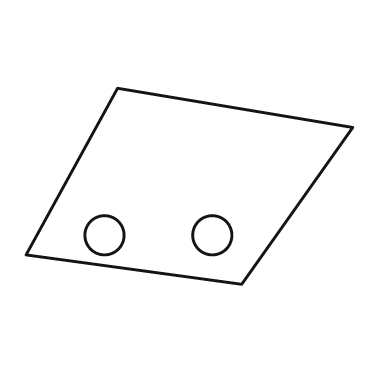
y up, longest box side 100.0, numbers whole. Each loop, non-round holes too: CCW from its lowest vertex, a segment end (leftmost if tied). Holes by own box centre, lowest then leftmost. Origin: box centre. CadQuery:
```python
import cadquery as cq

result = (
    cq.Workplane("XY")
    .moveTo(16.0, -30.0)
    .lineTo(50.0, 18.0)
    .lineTo(-22.0, 30.0)
    .lineTo(-50.0, -21.0)
    .close()
    .moveTo(-26.0, -15.0)
    .circle(6.0)
    .moveTo(7.0, -15.0)
    .circle(6.0)
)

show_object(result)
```